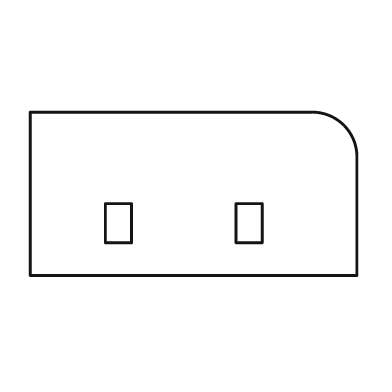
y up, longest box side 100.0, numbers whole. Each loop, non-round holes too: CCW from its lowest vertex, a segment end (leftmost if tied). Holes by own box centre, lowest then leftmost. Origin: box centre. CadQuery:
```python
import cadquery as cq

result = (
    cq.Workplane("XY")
    .moveTo(-50.0, -25.0)
    .lineTo(50.0, -25.0)
    .lineTo(50.0, 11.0)
    .threePointArc((46.0, 21.0), (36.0, 25.0))
    .lineTo(-50.0, 25.0)
    .close()
    .moveTo(-27.0, -15.0)
    .lineTo(-19.0, -15.0)
    .lineTo(-19.0, -3.0)
    .lineTo(-27.0, -3.0)
    .close()
    .moveTo(13.0, -15.0)
    .lineTo(21.0, -15.0)
    .lineTo(21.0, -3.0)
    .lineTo(13.0, -3.0)
    .close()
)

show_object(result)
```